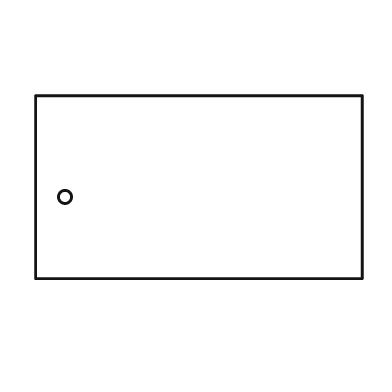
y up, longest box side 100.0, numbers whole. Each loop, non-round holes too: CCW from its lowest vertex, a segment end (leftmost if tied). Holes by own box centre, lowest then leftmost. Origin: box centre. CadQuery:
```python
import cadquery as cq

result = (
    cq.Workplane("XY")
    .moveTo(-50.0, -28.0)
    .lineTo(50.0, -28.0)
    .lineTo(50.0, 28.0)
    .lineTo(-50.0, 28.0)
    .close()
    .moveTo(-41.0, -3.0)
    .circle(2.0)
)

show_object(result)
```